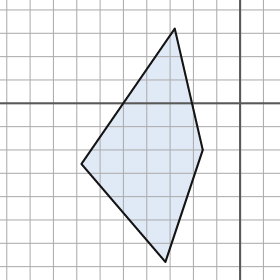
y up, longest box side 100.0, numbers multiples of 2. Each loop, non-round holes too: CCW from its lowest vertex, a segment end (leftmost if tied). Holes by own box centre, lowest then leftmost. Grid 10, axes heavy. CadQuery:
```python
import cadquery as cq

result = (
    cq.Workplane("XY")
    .moveTo(-32.0, -68.0)
    .lineTo(-16.0, -20.0)
    .lineTo(-28.0, 32.0)
    .lineTo(-68.0, -26.0)
    .close()
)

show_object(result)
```